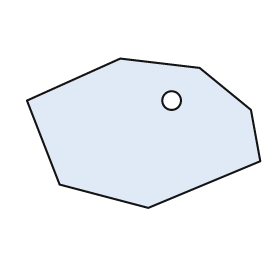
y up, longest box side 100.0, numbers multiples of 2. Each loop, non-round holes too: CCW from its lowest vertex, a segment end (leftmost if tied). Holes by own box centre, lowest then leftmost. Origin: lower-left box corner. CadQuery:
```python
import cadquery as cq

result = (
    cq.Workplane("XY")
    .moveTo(52.0, 0.0)
    .lineTo(100.0, 20.0)
    .lineTo(96.0, 42.0)
    .lineTo(74.0, 60.0)
    .lineTo(40.0, 64.0)
    .lineTo(0.0, 46.0)
    .lineTo(14.0, 10.0)
    .close()
    .moveTo(62.0, 46.0)
    .circle(4.0)
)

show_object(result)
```